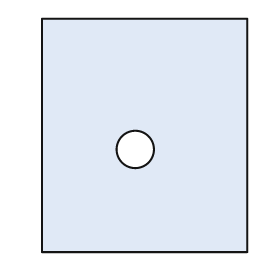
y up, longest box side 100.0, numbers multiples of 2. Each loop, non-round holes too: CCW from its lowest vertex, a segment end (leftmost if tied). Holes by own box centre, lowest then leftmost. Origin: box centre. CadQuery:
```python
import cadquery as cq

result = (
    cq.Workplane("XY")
    .moveTo(-44.0, -50.0)
    .lineTo(44.0, -50.0)
    .lineTo(44.0, 50.0)
    .lineTo(-44.0, 50.0)
    .close()
    .moveTo(-4.0, -6.0)
    .circle(8.0)
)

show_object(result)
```